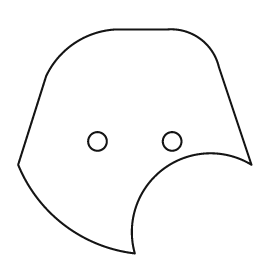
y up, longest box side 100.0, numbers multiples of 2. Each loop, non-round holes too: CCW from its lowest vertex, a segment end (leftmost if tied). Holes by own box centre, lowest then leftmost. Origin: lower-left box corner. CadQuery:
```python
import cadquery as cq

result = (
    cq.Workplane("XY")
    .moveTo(50.0, 0.0)
    .threePointArc((62.0, 36.0), (100.0, 38.0))
    .lineTo(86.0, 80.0)
    .threePointArc((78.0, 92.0), (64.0, 96.0))
    .lineTo(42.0, 96.0)
    .threePointArc((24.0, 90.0), (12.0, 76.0))
    .lineTo(0.0, 38.0)
    .threePointArc((20.0, 12.0), (50.0, 0.0))
    .close()
    .moveTo(34.0, 48.0)
    .circle(4.0)
    .moveTo(66.0, 48.0)
    .circle(4.0)
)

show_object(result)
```